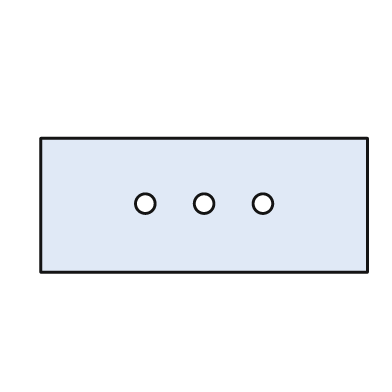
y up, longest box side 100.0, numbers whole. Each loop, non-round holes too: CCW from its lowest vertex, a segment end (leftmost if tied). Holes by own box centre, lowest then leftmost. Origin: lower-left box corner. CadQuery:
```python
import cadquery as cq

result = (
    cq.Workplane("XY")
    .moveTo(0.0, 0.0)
    .lineTo(100.0, 0.0)
    .lineTo(100.0, 41.0)
    .lineTo(0.0, 41.0)
    .close()
    .moveTo(32.0, 21.0)
    .circle(3.0)
    .moveTo(50.0, 21.0)
    .circle(3.0)
    .moveTo(68.0, 21.0)
    .circle(3.0)
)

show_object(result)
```